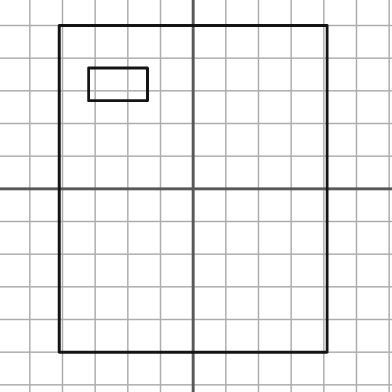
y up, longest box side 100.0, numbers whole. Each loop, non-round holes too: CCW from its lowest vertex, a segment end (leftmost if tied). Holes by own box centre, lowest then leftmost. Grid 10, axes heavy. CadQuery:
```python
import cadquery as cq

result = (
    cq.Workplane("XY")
    .moveTo(-41.0, -50.0)
    .lineTo(41.0, -50.0)
    .lineTo(41.0, 50.0)
    .lineTo(-41.0, 50.0)
    .close()
    .moveTo(-32.0, 27.0)
    .lineTo(-14.0, 27.0)
    .lineTo(-14.0, 37.0)
    .lineTo(-32.0, 37.0)
    .close()
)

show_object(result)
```